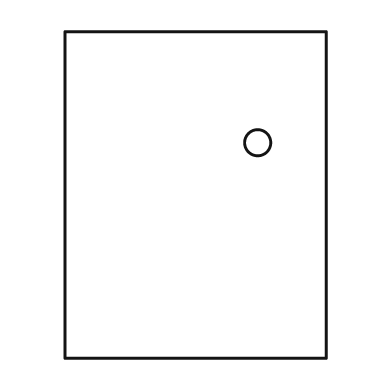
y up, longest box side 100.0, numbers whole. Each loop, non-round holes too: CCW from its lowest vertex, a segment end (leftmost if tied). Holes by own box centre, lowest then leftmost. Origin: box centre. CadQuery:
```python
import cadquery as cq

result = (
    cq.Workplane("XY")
    .moveTo(-40.0, -50.0)
    .lineTo(40.0, -50.0)
    .lineTo(40.0, 50.0)
    .lineTo(-40.0, 50.0)
    .close()
    .moveTo(19.0, 16.0)
    .circle(4.0)
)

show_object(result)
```